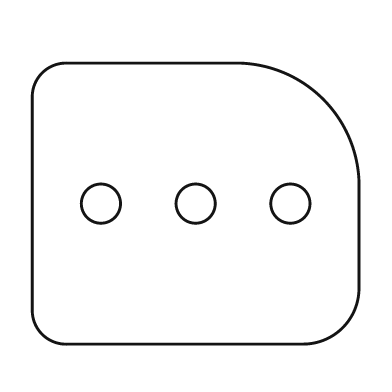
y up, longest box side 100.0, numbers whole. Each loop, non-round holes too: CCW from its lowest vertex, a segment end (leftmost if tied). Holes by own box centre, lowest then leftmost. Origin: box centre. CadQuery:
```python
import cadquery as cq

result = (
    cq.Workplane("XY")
    .moveTo(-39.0, -43.0)
    .lineTo(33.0, -43.0)
    .threePointArc((45.0, -38.0), (50.0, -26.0))
    .lineTo(50.0, 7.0)
    .threePointArc((39.0, 32.0), (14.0, 43.0))
    .lineTo(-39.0, 43.0)
    .threePointArc((-47.0, 40.0), (-50.0, 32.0))
    .lineTo(-50.0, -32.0)
    .threePointArc((-47.0, -40.0), (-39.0, -43.0))
    .close()
    .moveTo(-29.0, 0.0)
    .circle(6.0)
    .moveTo(0.0, 0.0)
    .circle(6.0)
    .moveTo(29.0, 0.0)
    .circle(6.0)
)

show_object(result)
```